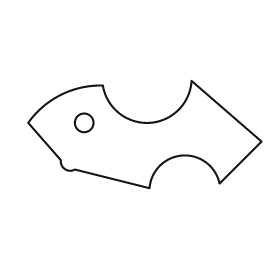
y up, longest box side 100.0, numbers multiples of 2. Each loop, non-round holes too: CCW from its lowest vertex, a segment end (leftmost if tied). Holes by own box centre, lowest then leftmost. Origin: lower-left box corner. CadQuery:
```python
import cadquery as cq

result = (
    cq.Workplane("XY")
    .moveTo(52.0, 0.0)
    .threePointArc((66.0, 14.0), (82.0, 2.0))
    .lineTo(100.0, 20.0)
    .lineTo(70.0, 46.0)
    .threePointArc((52.0, 28.0), (32.0, 44.0))
    .threePointArc((14.0, 40.0), (0.0, 28.0))
    .lineTo(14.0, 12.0)
    .threePointArc((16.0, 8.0), (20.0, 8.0))
    .close()
    .moveTo(24.0, 28.0)
    .circle(4.0)
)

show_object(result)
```